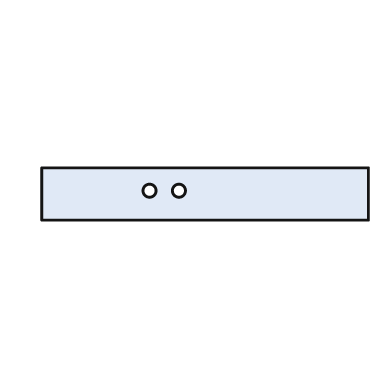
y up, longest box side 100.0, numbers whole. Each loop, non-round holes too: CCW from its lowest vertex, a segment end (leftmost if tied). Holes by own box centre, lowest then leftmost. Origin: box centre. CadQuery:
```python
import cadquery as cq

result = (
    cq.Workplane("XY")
    .moveTo(-50.0, -8.0)
    .lineTo(50.0, -8.0)
    .lineTo(50.0, 8.0)
    .lineTo(-50.0, 8.0)
    .close()
    .moveTo(-17.0, 1.0)
    .circle(2.0)
    .moveTo(-8.0, 1.0)
    .circle(2.0)
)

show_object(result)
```